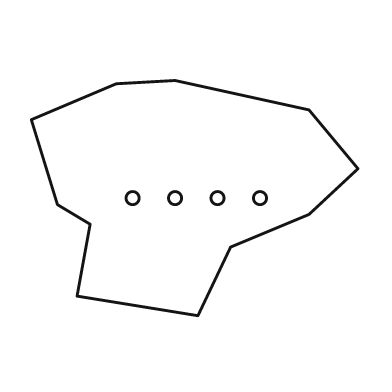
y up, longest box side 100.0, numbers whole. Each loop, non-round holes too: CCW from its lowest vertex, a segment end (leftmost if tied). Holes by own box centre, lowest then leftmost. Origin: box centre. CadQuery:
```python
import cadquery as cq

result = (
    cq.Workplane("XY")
    .moveTo(1.0, -36.0)
    .lineTo(11.0, -15.0)
    .lineTo(35.0, -5.0)
    .lineTo(50.0, 9.0)
    .lineTo(35.0, 27.0)
    .lineTo(-6.0, 36.0)
    .lineTo(-24.0, 35.0)
    .lineTo(-50.0, 24.0)
    .lineTo(-42.0, -2.0)
    .lineTo(-32.0, -8.0)
    .lineTo(-36.0, -30.0)
    .close()
    .moveTo(-19.0, 0.0)
    .circle(2.0)
    .moveTo(-6.0, 0.0)
    .circle(2.0)
    .moveTo(7.0, 0.0)
    .circle(2.0)
    .moveTo(20.0, 0.0)
    .circle(2.0)
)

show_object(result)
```